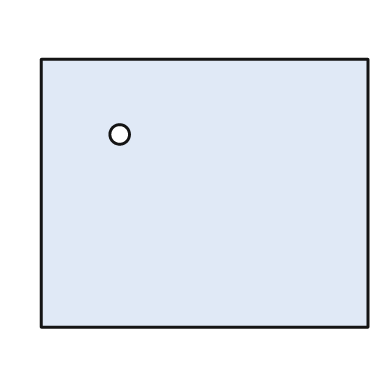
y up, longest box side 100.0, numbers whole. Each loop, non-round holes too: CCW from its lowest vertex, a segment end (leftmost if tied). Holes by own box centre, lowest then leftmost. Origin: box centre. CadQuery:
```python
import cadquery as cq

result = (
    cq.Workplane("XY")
    .moveTo(-50.0, -41.0)
    .lineTo(50.0, -41.0)
    .lineTo(50.0, 41.0)
    .lineTo(-50.0, 41.0)
    .close()
    .moveTo(-26.0, 18.0)
    .circle(3.0)
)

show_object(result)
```